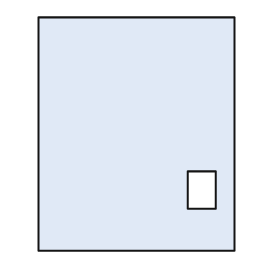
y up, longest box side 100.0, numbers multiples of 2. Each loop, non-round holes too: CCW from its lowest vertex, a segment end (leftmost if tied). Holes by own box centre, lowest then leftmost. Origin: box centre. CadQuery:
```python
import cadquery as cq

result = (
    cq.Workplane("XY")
    .moveTo(-42.0, -50.0)
    .lineTo(42.0, -50.0)
    .lineTo(42.0, 50.0)
    .lineTo(-42.0, 50.0)
    .close()
    .moveTo(22.0, -32.0)
    .lineTo(34.0, -32.0)
    .lineTo(34.0, -16.0)
    .lineTo(22.0, -16.0)
    .close()
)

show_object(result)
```